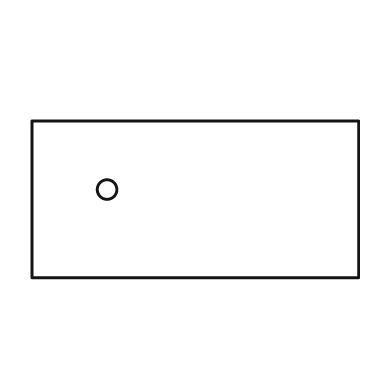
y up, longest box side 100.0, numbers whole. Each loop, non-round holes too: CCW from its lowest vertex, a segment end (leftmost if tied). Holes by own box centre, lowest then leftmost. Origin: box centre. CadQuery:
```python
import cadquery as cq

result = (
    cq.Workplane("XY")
    .moveTo(-50.0, -24.0)
    .lineTo(50.0, -24.0)
    .lineTo(50.0, 24.0)
    .lineTo(-50.0, 24.0)
    .close()
    .moveTo(-27.0, 3.0)
    .circle(3.0)
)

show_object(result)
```